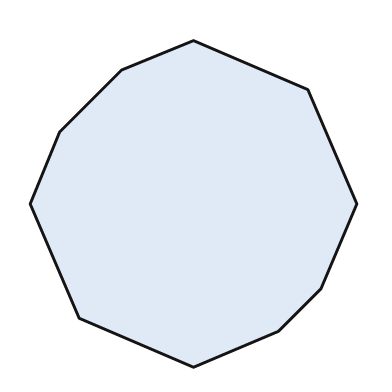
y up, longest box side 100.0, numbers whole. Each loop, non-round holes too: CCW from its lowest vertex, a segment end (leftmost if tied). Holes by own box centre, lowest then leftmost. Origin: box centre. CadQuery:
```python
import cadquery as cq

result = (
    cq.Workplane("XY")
    .moveTo(0.0, -50.0)
    .lineTo(26.0, -39.0)
    .lineTo(39.0, -26.0)
    .lineTo(50.0, 0.0)
    .lineTo(35.0, 35.0)
    .lineTo(0.0, 50.0)
    .lineTo(-22.0, 41.0)
    .lineTo(-41.0, 22.0)
    .lineTo(-50.0, 0.0)
    .lineTo(-35.0, -35.0)
    .close()
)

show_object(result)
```